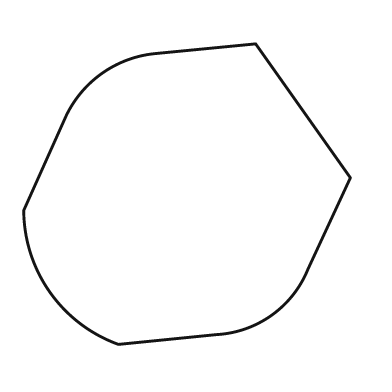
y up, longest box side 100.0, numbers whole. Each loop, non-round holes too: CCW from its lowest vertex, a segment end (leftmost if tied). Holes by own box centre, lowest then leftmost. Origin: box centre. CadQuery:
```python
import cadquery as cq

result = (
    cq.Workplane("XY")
    .moveTo(-21.0, -46.0)
    .lineTo(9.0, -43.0)
    .threePointArc((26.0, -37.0), (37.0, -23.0))
    .lineTo(50.0, 5.0)
    .lineTo(21.0, 46.0)
    .lineTo(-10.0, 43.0)
    .threePointArc((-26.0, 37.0), (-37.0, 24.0))
    .lineTo(-50.0, -5.0)
    .threePointArc((-42.0, -30.0), (-21.0, -46.0))
    .close()
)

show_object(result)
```